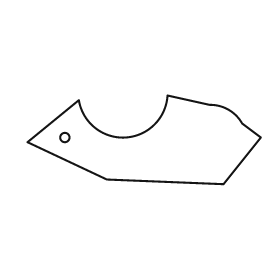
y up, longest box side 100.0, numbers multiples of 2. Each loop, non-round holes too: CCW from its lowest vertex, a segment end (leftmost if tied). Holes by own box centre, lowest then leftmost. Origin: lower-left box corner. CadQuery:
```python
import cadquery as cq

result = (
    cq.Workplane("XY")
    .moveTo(84.0, 0.0)
    .lineTo(100.0, 20.0)
    .lineTo(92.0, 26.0)
    .threePointArc((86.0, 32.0), (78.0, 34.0))
    .lineTo(60.0, 38.0)
    .threePointArc((42.0, 20.0), (22.0, 36.0))
    .lineTo(0.0, 18.0)
    .lineTo(34.0, 2.0)
    .close()
    .moveTo(16.0, 20.0)
    .circle(2.0)
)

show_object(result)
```